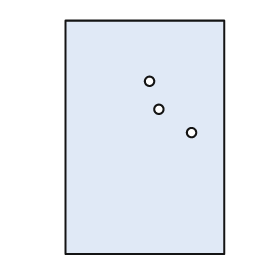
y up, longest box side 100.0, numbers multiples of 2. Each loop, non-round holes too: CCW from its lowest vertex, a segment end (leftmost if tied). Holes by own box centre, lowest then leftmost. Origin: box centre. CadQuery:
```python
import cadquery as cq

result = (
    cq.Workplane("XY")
    .moveTo(-34.0, -50.0)
    .lineTo(34.0, -50.0)
    .lineTo(34.0, 50.0)
    .lineTo(-34.0, 50.0)
    .close()
    .moveTo(20.0, 2.0)
    .circle(2.0)
    .moveTo(6.0, 12.0)
    .circle(2.0)
    .moveTo(2.0, 24.0)
    .circle(2.0)
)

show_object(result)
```